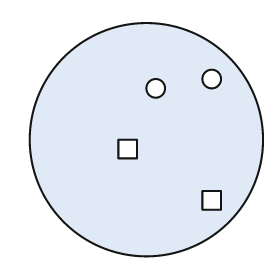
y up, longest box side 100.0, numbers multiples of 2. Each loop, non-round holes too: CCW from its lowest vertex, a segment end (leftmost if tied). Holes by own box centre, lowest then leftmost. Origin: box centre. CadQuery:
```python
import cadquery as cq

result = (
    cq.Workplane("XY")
    .moveTo(0.0, 0.0)
    .circle(50.0)
    .moveTo(24.0, -30.0)
    .lineTo(32.0, -30.0)
    .lineTo(32.0, -22.0)
    .lineTo(24.0, -22.0)
    .close()
    .moveTo(-12.0, -8.0)
    .lineTo(-4.0, -8.0)
    .lineTo(-4.0, 0.0)
    .lineTo(-12.0, 0.0)
    .close()
    .moveTo(4.0, 22.0)
    .circle(4.0)
    .moveTo(28.0, 26.0)
    .circle(4.0)
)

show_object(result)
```